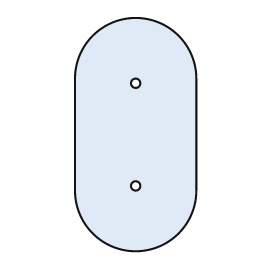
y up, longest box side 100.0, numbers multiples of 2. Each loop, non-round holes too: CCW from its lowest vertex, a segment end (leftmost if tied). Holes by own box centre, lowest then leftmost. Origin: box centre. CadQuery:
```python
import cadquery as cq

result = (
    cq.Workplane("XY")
    .moveTo(-26.0, -24.0)
    .threePointArc((0.0, -50.0), (26.0, -24.0))
    .lineTo(26.0, 24.0)
    .threePointArc((0.0, 50.0), (-26.0, 24.0))
    .close()
    .moveTo(0.0, -22.0)
    .circle(2.0)
    .moveTo(0.0, 22.0)
    .circle(2.0)
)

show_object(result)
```